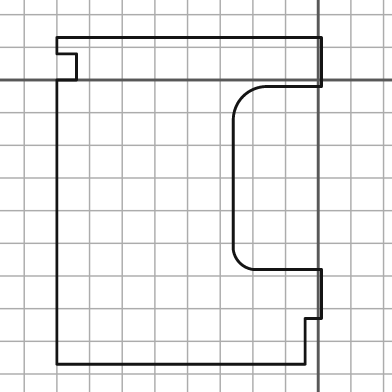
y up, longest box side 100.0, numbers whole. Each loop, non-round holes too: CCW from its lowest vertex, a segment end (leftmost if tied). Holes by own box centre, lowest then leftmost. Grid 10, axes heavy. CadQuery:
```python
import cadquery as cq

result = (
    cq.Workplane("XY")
    .moveTo(-80.0, -87.0)
    .lineTo(-4.0, -87.0)
    .lineTo(-4.0, -73.0)
    .lineTo(1.0, -73.0)
    .lineTo(1.0, -58.0)
    .lineTo(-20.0, -58.0)
    .threePointArc((-24.0, -56.0), (-26.0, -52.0))
    .lineTo(-26.0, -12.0)
    .threePointArc((-23.0, -5.0), (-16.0, -2.0))
    .lineTo(1.0, -2.0)
    .lineTo(1.0, 13.0)
    .lineTo(-80.0, 13.0)
    .lineTo(-80.0, 8.0)
    .lineTo(-74.0, 8.0)
    .lineTo(-74.0, 0.0)
    .lineTo(-80.0, 0.0)
    .close()
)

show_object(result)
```